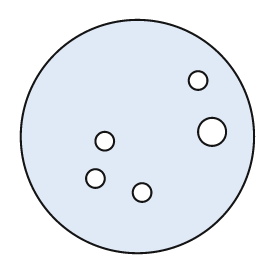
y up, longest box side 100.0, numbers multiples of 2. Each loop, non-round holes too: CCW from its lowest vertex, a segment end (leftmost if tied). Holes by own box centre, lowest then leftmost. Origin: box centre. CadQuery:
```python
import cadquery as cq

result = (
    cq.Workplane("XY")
    .moveTo(0.0, 0.0)
    .circle(50.0)
    .moveTo(2.0, -24.0)
    .circle(4.0)
    .moveTo(-18.0, -18.0)
    .circle(4.0)
    .moveTo(-14.0, -2.0)
    .circle(4.0)
    .moveTo(32.0, 2.0)
    .circle(6.0)
    .moveTo(26.0, 24.0)
    .circle(4.0)
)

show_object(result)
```